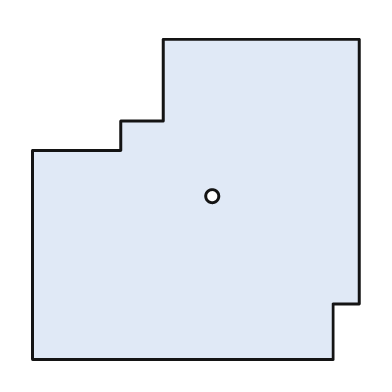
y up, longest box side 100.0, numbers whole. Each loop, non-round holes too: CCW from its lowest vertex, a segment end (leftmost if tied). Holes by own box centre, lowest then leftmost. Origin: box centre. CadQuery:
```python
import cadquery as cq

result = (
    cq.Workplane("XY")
    .moveTo(-50.0, -49.0)
    .lineTo(42.0, -49.0)
    .lineTo(42.0, -32.0)
    .lineTo(50.0, -32.0)
    .lineTo(50.0, 49.0)
    .lineTo(-10.0, 49.0)
    .lineTo(-10.0, 24.0)
    .lineTo(-23.0, 24.0)
    .lineTo(-23.0, 15.0)
    .lineTo(-50.0, 15.0)
    .close()
    .moveTo(5.0, 1.0)
    .circle(2.0)
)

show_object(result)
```